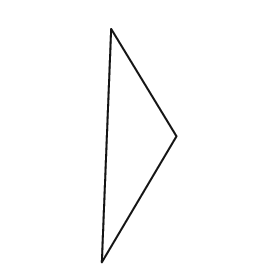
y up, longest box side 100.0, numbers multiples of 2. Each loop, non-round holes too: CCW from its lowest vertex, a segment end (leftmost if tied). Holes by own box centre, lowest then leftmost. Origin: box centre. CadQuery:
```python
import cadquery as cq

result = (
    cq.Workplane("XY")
    .moveTo(-16.0, -50.0)
    .lineTo(16.0, 4.0)
    .lineTo(-12.0, 50.0)
    .close()
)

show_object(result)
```